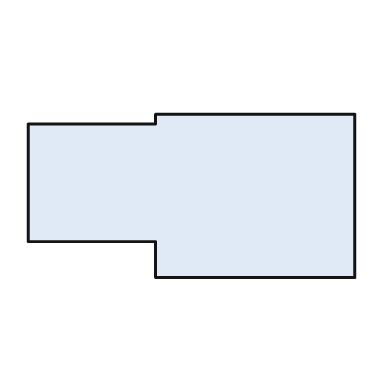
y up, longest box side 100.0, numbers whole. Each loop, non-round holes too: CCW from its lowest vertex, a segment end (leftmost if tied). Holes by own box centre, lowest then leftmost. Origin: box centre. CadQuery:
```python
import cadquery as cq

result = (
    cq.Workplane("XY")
    .moveTo(-11.0, -25.0)
    .lineTo(50.0, -25.0)
    .lineTo(50.0, 25.0)
    .lineTo(-11.0, 25.0)
    .lineTo(-11.0, 22.0)
    .lineTo(-50.0, 22.0)
    .lineTo(-50.0, -14.0)
    .lineTo(-11.0, -14.0)
    .close()
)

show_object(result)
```